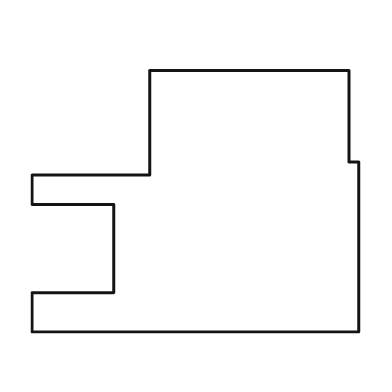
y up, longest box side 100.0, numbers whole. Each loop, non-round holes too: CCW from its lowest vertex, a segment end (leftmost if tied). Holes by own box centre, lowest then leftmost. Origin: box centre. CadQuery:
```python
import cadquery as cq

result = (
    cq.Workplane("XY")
    .moveTo(-50.0, -40.0)
    .lineTo(50.0, -40.0)
    .lineTo(50.0, 12.0)
    .lineTo(47.0, 12.0)
    .lineTo(47.0, 40.0)
    .lineTo(-14.0, 40.0)
    .lineTo(-14.0, 8.0)
    .lineTo(-50.0, 8.0)
    .lineTo(-50.0, -1.0)
    .lineTo(-25.0, -1.0)
    .lineTo(-25.0, -28.0)
    .lineTo(-50.0, -28.0)
    .close()
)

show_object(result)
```